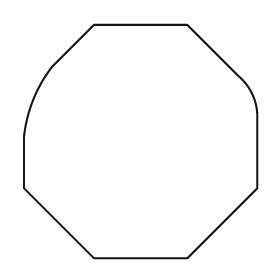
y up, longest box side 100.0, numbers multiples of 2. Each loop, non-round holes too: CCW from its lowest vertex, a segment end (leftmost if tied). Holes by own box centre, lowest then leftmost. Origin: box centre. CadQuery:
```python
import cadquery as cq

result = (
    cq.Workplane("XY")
    .moveTo(-20.0, -50.0)
    .lineTo(20.0, -50.0)
    .lineTo(50.0, -20.0)
    .lineTo(50.0, 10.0)
    .threePointArc((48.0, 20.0), (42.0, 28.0))
    .lineTo(20.0, 50.0)
    .lineTo(-20.0, 50.0)
    .lineTo(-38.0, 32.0)
    .threePointArc((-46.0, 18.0), (-50.0, 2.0))
    .lineTo(-50.0, -20.0)
    .close()
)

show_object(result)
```